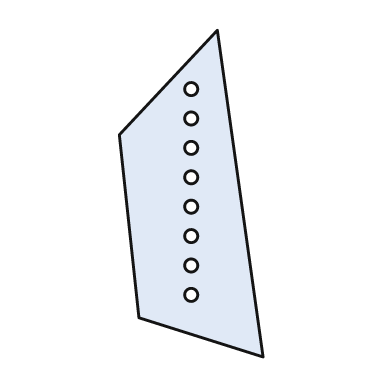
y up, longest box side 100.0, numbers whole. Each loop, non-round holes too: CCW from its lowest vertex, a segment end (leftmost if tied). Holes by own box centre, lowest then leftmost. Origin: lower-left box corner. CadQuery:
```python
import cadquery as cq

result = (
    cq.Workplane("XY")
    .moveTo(44.0, 0.0)
    .lineTo(30.0, 100.0)
    .lineTo(0.0, 68.0)
    .lineTo(6.0, 12.0)
    .close()
    .moveTo(22.0, 19.0)
    .circle(2.0)
    .moveTo(22.0, 28.0)
    .circle(2.0)
    .moveTo(22.0, 37.0)
    .circle(2.0)
    .moveTo(22.0, 46.0)
    .circle(2.0)
    .moveTo(22.0, 55.0)
    .circle(2.0)
    .moveTo(22.0, 64.0)
    .circle(2.0)
    .moveTo(22.0, 73.0)
    .circle(2.0)
    .moveTo(22.0, 82.0)
    .circle(2.0)
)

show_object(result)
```